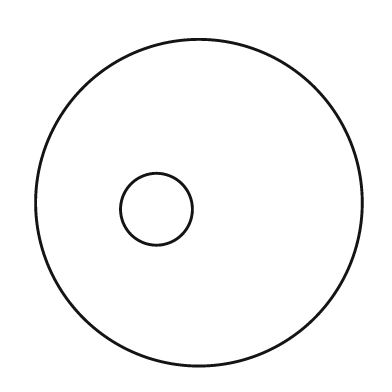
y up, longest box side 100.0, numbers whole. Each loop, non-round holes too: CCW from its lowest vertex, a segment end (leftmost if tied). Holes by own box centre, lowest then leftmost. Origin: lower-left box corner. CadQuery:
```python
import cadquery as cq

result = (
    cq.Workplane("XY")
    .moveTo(50.0, 50.0)
    .circle(50.0)
    .moveTo(37.0, 48.0)
    .circle(11.0)
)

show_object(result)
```